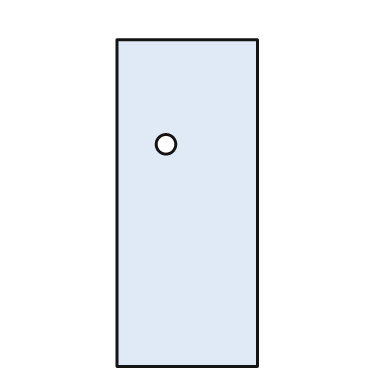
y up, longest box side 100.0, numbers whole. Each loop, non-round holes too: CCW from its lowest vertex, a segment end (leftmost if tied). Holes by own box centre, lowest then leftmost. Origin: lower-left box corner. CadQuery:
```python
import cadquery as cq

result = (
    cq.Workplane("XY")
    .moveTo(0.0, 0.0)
    .lineTo(43.0, 0.0)
    .lineTo(43.0, 100.0)
    .lineTo(0.0, 100.0)
    .close()
    .moveTo(15.0, 68.0)
    .circle(3.0)
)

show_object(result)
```